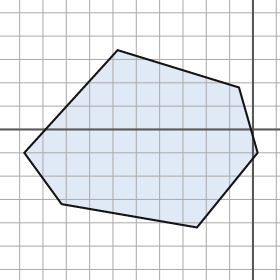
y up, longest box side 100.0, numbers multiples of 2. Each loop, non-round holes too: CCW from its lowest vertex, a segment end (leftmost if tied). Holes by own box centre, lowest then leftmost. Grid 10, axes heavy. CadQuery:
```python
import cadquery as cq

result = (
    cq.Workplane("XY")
    .moveTo(-24.0, -42.0)
    .lineTo(2.0, -10.0)
    .lineTo(-6.0, 18.0)
    .lineTo(-58.0, 34.0)
    .lineTo(-98.0, -10.0)
    .lineTo(-82.0, -32.0)
    .close()
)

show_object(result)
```